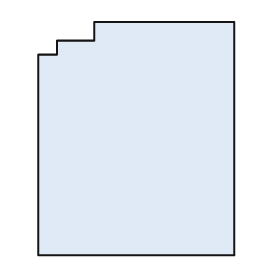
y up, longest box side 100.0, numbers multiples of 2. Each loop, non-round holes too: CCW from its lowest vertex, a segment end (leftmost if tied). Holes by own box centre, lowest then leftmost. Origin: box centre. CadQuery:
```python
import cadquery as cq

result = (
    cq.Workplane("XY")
    .moveTo(-42.0, -50.0)
    .lineTo(42.0, -50.0)
    .lineTo(42.0, 50.0)
    .lineTo(-18.0, 50.0)
    .lineTo(-18.0, 42.0)
    .lineTo(-34.0, 42.0)
    .lineTo(-34.0, 36.0)
    .lineTo(-42.0, 36.0)
    .close()
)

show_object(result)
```